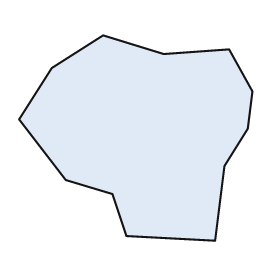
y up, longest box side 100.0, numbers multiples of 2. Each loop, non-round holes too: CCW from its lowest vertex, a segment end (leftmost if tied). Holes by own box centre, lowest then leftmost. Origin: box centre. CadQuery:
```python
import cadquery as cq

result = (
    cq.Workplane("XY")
    .moveTo(34.0, -44.0)
    .lineTo(38.0, -12.0)
    .lineTo(48.0, 4.0)
    .lineTo(50.0, 20.0)
    .lineTo(40.0, 38.0)
    .lineTo(12.0, 36.0)
    .lineTo(-14.0, 44.0)
    .lineTo(-36.0, 30.0)
    .lineTo(-50.0, 8.0)
    .lineTo(-30.0, -18.0)
    .lineTo(-10.0, -24.0)
    .lineTo(-4.0, -42.0)
    .close()
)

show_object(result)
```